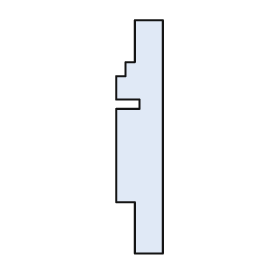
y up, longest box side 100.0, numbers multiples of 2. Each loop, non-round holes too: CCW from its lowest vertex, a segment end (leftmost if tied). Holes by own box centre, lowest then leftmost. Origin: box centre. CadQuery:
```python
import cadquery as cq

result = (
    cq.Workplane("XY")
    .moveTo(-2.0, -50.0)
    .lineTo(10.0, -50.0)
    .lineTo(10.0, 50.0)
    .lineTo(-2.0, 50.0)
    .lineTo(-2.0, 32.0)
    .lineTo(-6.0, 32.0)
    .lineTo(-6.0, 26.0)
    .lineTo(-10.0, 26.0)
    .lineTo(-10.0, 16.0)
    .lineTo(0.0, 16.0)
    .lineTo(0.0, 12.0)
    .lineTo(-10.0, 12.0)
    .lineTo(-10.0, -28.0)
    .lineTo(-2.0, -28.0)
    .close()
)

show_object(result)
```